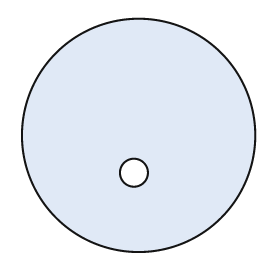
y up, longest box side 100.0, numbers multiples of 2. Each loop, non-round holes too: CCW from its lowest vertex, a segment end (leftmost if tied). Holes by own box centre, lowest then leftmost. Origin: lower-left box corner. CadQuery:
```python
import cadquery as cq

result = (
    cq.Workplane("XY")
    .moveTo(50.0, 50.0)
    .circle(50.0)
    .moveTo(48.0, 34.0)
    .circle(6.0)
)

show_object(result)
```